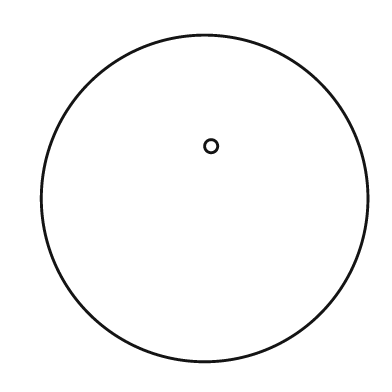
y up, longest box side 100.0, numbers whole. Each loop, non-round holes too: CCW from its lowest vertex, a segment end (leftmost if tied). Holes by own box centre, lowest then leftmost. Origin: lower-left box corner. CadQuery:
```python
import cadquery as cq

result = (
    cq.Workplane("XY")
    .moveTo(50.0, 50.0)
    .circle(50.0)
    .moveTo(52.0, 66.0)
    .circle(2.0)
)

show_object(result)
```